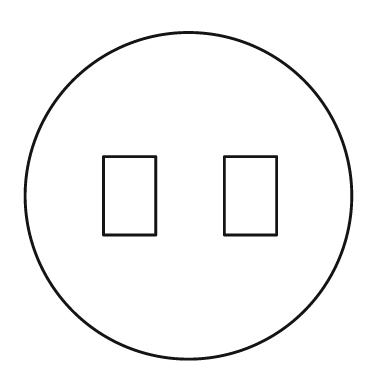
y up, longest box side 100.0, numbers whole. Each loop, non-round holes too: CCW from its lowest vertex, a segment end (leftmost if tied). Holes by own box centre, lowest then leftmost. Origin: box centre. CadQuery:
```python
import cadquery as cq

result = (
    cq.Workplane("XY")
    .moveTo(0.0, 0.0)
    .circle(50.0)
    .moveTo(-26.0, -12.0)
    .lineTo(-10.0, -12.0)
    .lineTo(-10.0, 12.0)
    .lineTo(-26.0, 12.0)
    .close()
    .moveTo(11.0, -12.0)
    .lineTo(27.0, -12.0)
    .lineTo(27.0, 12.0)
    .lineTo(11.0, 12.0)
    .close()
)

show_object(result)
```